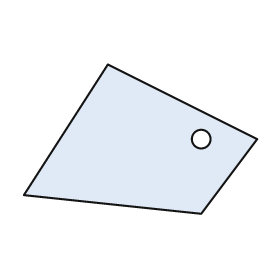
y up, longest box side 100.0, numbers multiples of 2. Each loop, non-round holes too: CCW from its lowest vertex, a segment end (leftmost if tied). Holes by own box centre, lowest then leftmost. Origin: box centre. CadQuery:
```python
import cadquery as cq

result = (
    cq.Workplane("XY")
    .moveTo(26.0, -32.0)
    .lineTo(50.0, 0.0)
    .lineTo(-14.0, 32.0)
    .lineTo(-50.0, -24.0)
    .close()
    .moveTo(26.0, 0.0)
    .circle(4.0)
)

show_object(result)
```